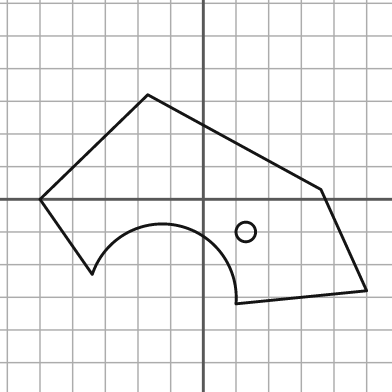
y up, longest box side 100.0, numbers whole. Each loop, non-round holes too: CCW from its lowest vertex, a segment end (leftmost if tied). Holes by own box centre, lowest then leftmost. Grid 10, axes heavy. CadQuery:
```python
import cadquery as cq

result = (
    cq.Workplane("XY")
    .moveTo(10.0, -32.0)
    .lineTo(50.0, -28.0)
    .lineTo(36.0, 3.0)
    .lineTo(-17.0, 32.0)
    .lineTo(-50.0, 0.0)
    .lineTo(-34.0, -23.0)
    .threePointArc((-8.0, -8.0), (10.0, -32.0))
    .close()
    .moveTo(13.0, -10.0)
    .circle(3.0)
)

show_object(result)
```